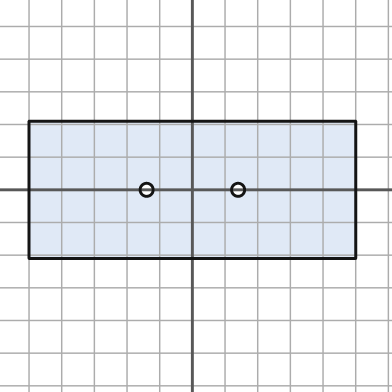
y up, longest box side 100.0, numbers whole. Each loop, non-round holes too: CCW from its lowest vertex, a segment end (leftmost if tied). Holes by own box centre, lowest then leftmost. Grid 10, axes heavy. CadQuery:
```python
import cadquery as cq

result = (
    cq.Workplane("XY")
    .moveTo(-50.0, -21.0)
    .lineTo(50.0, -21.0)
    .lineTo(50.0, 21.0)
    .lineTo(-50.0, 21.0)
    .close()
    .moveTo(-14.0, 0.0)
    .circle(2.0)
    .moveTo(14.0, 0.0)
    .circle(2.0)
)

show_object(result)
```